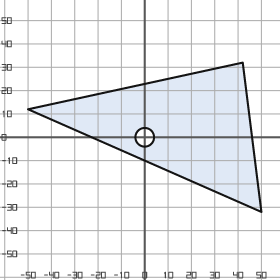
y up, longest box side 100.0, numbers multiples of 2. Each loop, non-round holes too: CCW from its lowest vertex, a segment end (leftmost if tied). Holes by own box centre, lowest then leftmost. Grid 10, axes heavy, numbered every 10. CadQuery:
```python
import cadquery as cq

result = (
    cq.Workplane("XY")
    .moveTo(50.0, -32.0)
    .lineTo(42.0, 32.0)
    .lineTo(-50.0, 12.0)
    .close()
    .moveTo(0.0, 0.0)
    .circle(4.0)
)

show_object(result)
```